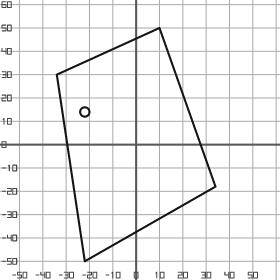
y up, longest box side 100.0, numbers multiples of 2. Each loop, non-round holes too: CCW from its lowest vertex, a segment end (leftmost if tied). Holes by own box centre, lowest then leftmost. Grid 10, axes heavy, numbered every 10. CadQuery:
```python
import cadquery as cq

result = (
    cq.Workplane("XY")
    .moveTo(-22.0, -50.0)
    .lineTo(34.0, -18.0)
    .lineTo(10.0, 50.0)
    .lineTo(-34.0, 30.0)
    .close()
    .moveTo(-22.0, 14.0)
    .circle(2.0)
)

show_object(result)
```